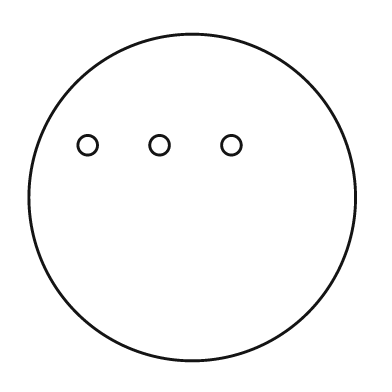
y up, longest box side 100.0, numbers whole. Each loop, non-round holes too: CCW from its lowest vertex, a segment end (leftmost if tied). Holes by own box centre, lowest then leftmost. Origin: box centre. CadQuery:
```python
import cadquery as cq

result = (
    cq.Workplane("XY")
    .moveTo(0.0, 0.0)
    .circle(50.0)
    .moveTo(-32.0, 16.0)
    .circle(3.0)
    .moveTo(-10.0, 16.0)
    .circle(3.0)
    .moveTo(12.0, 16.0)
    .circle(3.0)
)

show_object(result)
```